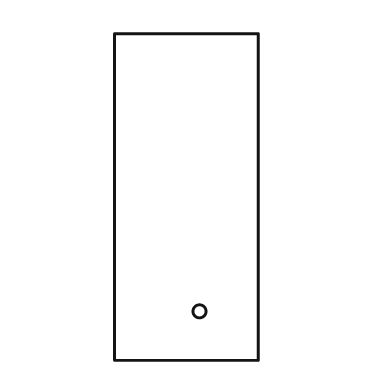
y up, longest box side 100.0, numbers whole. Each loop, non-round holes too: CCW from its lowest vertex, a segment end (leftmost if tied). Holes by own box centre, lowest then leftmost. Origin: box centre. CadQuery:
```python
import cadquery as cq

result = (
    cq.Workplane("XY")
    .moveTo(-22.0, -50.0)
    .lineTo(22.0, -50.0)
    .lineTo(22.0, 50.0)
    .lineTo(-22.0, 50.0)
    .close()
    .moveTo(4.0, -35.0)
    .circle(2.0)
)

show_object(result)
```